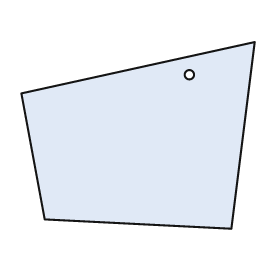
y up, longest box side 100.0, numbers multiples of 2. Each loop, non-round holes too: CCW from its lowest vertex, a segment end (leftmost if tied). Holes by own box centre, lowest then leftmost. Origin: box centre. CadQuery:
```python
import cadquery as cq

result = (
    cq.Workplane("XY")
    .moveTo(40.0, -40.0)
    .lineTo(50.0, 40.0)
    .lineTo(-50.0, 18.0)
    .lineTo(-40.0, -36.0)
    .close()
    .moveTo(22.0, 26.0)
    .circle(2.0)
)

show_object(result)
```